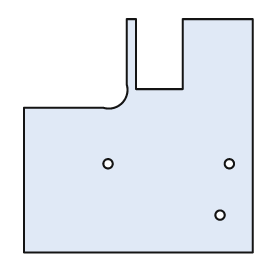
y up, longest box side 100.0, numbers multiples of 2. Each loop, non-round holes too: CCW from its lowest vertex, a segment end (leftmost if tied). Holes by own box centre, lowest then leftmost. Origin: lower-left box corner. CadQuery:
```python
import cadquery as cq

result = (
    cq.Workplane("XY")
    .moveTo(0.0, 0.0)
    .lineTo(98.0, 0.0)
    .lineTo(98.0, 100.0)
    .lineTo(68.0, 100.0)
    .lineTo(68.0, 70.0)
    .lineTo(48.0, 70.0)
    .lineTo(48.0, 100.0)
    .lineTo(44.0, 100.0)
    .lineTo(44.0, 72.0)
    .threePointArc((42.0, 64.0), (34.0, 62.0))
    .lineTo(0.0, 62.0)
    .close()
    .moveTo(84.0, 16.0)
    .circle(2.0)
    .moveTo(36.0, 38.0)
    .circle(2.0)
    .moveTo(88.0, 38.0)
    .circle(2.0)
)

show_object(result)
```